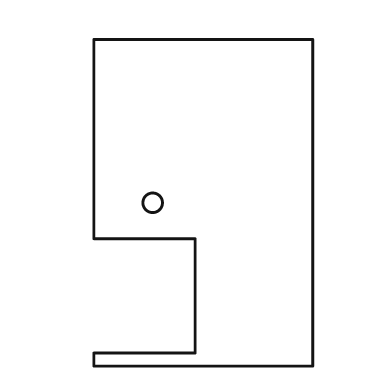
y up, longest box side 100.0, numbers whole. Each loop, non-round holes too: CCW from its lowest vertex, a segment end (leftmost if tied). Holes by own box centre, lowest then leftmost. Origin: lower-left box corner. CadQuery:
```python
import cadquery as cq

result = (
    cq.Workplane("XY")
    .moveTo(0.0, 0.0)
    .lineTo(67.0, 0.0)
    .lineTo(67.0, 100.0)
    .lineTo(0.0, 100.0)
    .lineTo(0.0, 39.0)
    .lineTo(31.0, 39.0)
    .lineTo(31.0, 4.0)
    .lineTo(0.0, 4.0)
    .close()
    .moveTo(18.0, 50.0)
    .circle(3.0)
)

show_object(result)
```